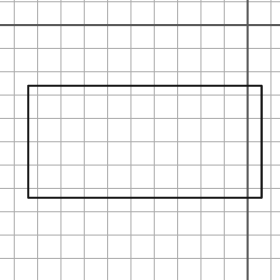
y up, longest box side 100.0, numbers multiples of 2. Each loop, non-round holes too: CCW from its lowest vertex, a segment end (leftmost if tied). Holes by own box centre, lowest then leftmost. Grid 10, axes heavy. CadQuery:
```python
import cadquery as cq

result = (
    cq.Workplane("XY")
    .moveTo(-94.0, -74.0)
    .lineTo(6.0, -74.0)
    .lineTo(6.0, -26.0)
    .lineTo(-94.0, -26.0)
    .close()
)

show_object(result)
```